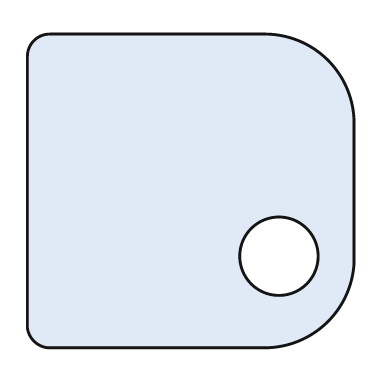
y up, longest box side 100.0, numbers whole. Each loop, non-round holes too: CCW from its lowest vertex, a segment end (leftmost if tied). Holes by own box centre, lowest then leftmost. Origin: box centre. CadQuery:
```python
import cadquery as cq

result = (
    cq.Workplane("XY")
    .moveTo(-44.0, -48.0)
    .lineTo(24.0, -48.0)
    .threePointArc((42.0, -40.0), (50.0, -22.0))
    .lineTo(50.0, 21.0)
    .threePointArc((42.0, 40.0), (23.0, 48.0))
    .lineTo(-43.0, 48.0)
    .threePointArc((-48.0, 46.0), (-50.0, 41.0))
    .lineTo(-50.0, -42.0)
    .threePointArc((-48.0, -46.0), (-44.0, -48.0))
    .close()
    .moveTo(27.0, -20.0)
    .circle(12.0)
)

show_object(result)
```